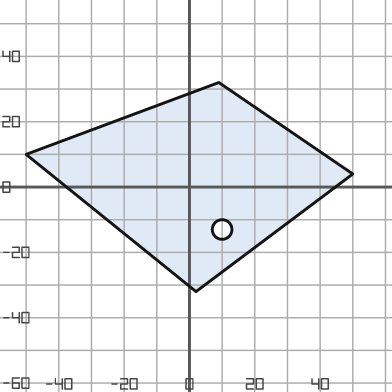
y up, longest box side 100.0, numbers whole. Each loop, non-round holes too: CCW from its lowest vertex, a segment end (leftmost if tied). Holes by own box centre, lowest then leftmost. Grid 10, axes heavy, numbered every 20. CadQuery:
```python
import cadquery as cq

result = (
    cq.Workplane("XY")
    .moveTo(2.0, -32.0)
    .lineTo(50.0, 4.0)
    .lineTo(9.0, 32.0)
    .lineTo(-50.0, 10.0)
    .close()
    .moveTo(10.0, -13.0)
    .circle(3.0)
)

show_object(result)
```